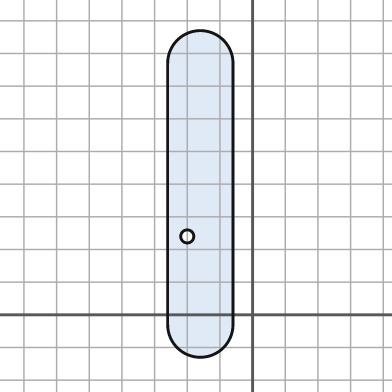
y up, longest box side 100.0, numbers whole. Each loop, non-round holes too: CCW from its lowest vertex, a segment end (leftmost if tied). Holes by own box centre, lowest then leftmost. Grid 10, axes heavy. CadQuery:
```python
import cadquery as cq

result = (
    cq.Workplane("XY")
    .moveTo(-26.0, -3.0)
    .threePointArc((-16.0, -13.0), (-6.0, -3.0))
    .lineTo(-6.0, 77.0)
    .threePointArc((-16.0, 87.0), (-26.0, 77.0))
    .close()
    .moveTo(-20.0, 24.0)
    .circle(2.0)
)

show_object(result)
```